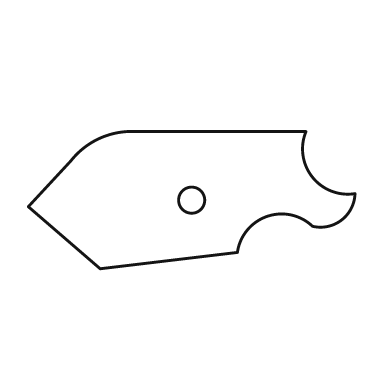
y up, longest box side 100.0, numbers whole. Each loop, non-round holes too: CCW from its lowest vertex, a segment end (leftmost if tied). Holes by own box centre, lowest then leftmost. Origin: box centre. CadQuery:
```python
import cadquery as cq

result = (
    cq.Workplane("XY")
    .moveTo(-28.0, -21.0)
    .lineTo(14.0, -16.0)
    .threePointArc((23.0, -5.0), (37.0, -8.0))
    .threePointArc((46.0, -6.0), (50.0, 2.0))
    .threePointArc((37.0, 7.0), (35.0, 21.0))
    .lineTo(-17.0, 21.0)
    .threePointArc((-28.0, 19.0), (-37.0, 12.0))
    .lineTo(-50.0, -2.0)
    .close()
    .moveTo(0.0, 0.0)
    .circle(4.0)
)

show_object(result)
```